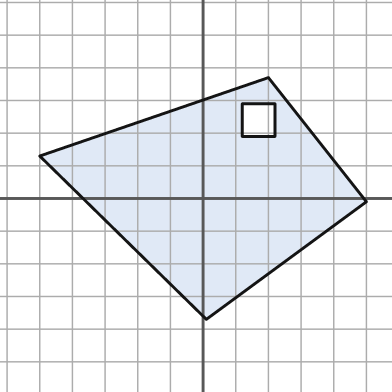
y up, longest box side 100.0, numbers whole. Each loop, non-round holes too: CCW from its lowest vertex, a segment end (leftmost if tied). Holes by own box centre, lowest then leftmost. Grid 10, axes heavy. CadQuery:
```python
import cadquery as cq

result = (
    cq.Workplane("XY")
    .moveTo(1.0, -37.0)
    .lineTo(50.0, -1.0)
    .lineTo(20.0, 37.0)
    .lineTo(-50.0, 13.0)
    .close()
    .moveTo(12.0, 19.0)
    .lineTo(22.0, 19.0)
    .lineTo(22.0, 29.0)
    .lineTo(12.0, 29.0)
    .close()
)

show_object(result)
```